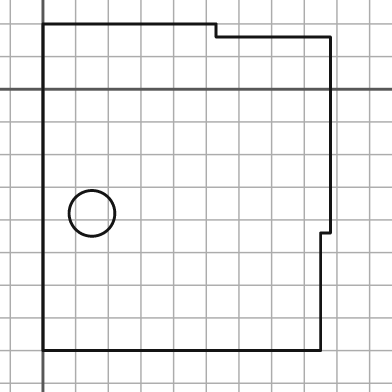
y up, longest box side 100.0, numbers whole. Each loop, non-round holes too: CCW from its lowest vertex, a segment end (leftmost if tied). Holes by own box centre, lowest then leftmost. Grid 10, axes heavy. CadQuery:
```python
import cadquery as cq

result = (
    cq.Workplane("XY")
    .moveTo(0.0, -80.0)
    .lineTo(85.0, -80.0)
    .lineTo(85.0, -44.0)
    .lineTo(88.0, -44.0)
    .lineTo(88.0, 16.0)
    .lineTo(53.0, 16.0)
    .lineTo(53.0, 20.0)
    .lineTo(0.0, 20.0)
    .close()
    .moveTo(15.0, -38.0)
    .circle(7.0)
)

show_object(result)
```